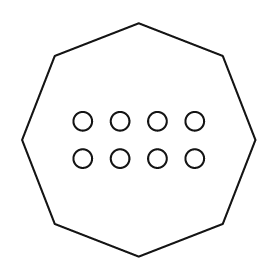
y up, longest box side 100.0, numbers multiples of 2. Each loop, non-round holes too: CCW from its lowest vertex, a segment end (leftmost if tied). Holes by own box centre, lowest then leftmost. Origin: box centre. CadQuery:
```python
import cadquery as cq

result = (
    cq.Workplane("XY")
    .moveTo(0.0, -50.0)
    .lineTo(36.0, -36.0)
    .lineTo(50.0, 0.0)
    .lineTo(36.0, 36.0)
    .lineTo(0.0, 50.0)
    .lineTo(-36.0, 36.0)
    .lineTo(-50.0, 0.0)
    .lineTo(-36.0, -36.0)
    .close()
    .moveTo(-24.0, -8.0)
    .circle(4.0)
    .moveTo(-8.0, -8.0)
    .circle(4.0)
    .moveTo(8.0, -8.0)
    .circle(4.0)
    .moveTo(24.0, -8.0)
    .circle(4.0)
    .moveTo(-24.0, 8.0)
    .circle(4.0)
    .moveTo(-8.0, 8.0)
    .circle(4.0)
    .moveTo(8.0, 8.0)
    .circle(4.0)
    .moveTo(24.0, 8.0)
    .circle(4.0)
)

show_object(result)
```